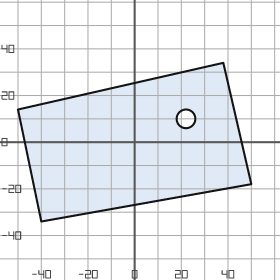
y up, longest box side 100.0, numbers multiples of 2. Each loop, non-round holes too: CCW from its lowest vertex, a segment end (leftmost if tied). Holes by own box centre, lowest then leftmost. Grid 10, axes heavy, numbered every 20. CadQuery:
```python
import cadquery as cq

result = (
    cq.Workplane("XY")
    .moveTo(-40.0, -34.0)
    .lineTo(50.0, -18.0)
    .lineTo(38.0, 34.0)
    .lineTo(-50.0, 14.0)
    .close()
    .moveTo(22.0, 10.0)
    .circle(4.0)
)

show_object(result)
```